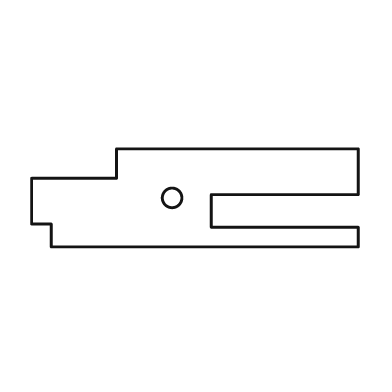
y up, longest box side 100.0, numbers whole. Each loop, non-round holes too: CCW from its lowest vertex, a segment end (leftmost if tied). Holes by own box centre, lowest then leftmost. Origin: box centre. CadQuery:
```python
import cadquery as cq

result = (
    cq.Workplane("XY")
    .moveTo(-44.0, -15.0)
    .lineTo(50.0, -15.0)
    .lineTo(50.0, -9.0)
    .lineTo(5.0, -9.0)
    .lineTo(5.0, 1.0)
    .lineTo(50.0, 1.0)
    .lineTo(50.0, 15.0)
    .lineTo(-24.0, 15.0)
    .lineTo(-24.0, 6.0)
    .lineTo(-50.0, 6.0)
    .lineTo(-50.0, -8.0)
    .lineTo(-44.0, -8.0)
    .close()
    .moveTo(-7.0, 0.0)
    .circle(3.0)
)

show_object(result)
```